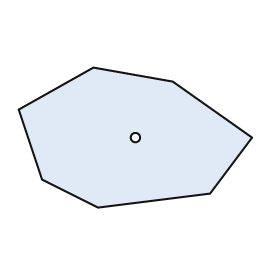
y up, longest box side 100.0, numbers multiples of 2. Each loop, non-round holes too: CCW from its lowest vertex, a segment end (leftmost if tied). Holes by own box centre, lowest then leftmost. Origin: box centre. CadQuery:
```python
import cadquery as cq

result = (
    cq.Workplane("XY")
    .moveTo(-16.0, -30.0)
    .lineTo(32.0, -24.0)
    .lineTo(50.0, 0.0)
    .lineTo(16.0, 24.0)
    .lineTo(-18.0, 30.0)
    .lineTo(-50.0, 12.0)
    .lineTo(-40.0, -18.0)
    .close()
    .moveTo(0.0, 0.0)
    .circle(2.0)
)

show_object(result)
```